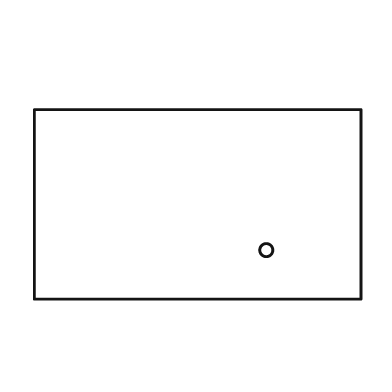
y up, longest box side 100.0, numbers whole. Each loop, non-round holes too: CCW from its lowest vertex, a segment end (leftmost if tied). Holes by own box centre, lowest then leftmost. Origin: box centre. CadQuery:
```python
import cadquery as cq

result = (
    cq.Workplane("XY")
    .moveTo(-50.0, -29.0)
    .lineTo(50.0, -29.0)
    .lineTo(50.0, 29.0)
    .lineTo(-50.0, 29.0)
    .close()
    .moveTo(21.0, -14.0)
    .circle(2.0)
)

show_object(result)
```